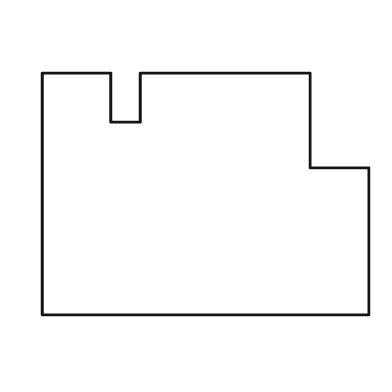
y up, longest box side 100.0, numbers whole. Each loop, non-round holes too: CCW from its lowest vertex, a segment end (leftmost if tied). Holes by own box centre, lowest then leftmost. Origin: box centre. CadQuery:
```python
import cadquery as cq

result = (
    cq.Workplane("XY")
    .moveTo(-50.0, -37.0)
    .lineTo(50.0, -37.0)
    .lineTo(50.0, 8.0)
    .lineTo(32.0, 8.0)
    .lineTo(32.0, 37.0)
    .lineTo(-20.0, 37.0)
    .lineTo(-20.0, 22.0)
    .lineTo(-29.0, 22.0)
    .lineTo(-29.0, 37.0)
    .lineTo(-50.0, 37.0)
    .close()
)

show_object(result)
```